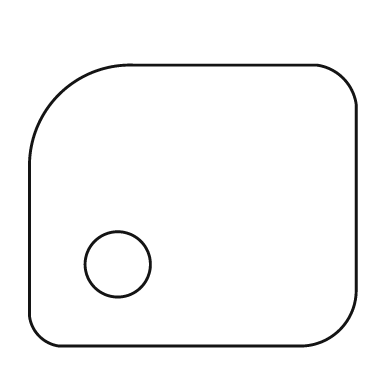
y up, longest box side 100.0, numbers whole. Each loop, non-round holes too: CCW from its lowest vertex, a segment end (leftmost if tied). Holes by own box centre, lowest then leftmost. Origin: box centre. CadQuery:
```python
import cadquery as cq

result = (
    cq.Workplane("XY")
    .moveTo(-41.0, -43.0)
    .lineTo(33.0, -43.0)
    .threePointArc((45.0, -38.0), (50.0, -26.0))
    .lineTo(50.0, 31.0)
    .threePointArc((46.0, 39.0), (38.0, 43.0))
    .lineTo(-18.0, 43.0)
    .threePointArc((-41.0, 34.0), (-50.0, 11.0))
    .lineTo(-50.0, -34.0)
    .threePointArc((-47.0, -40.0), (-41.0, -43.0))
    .close()
    .moveTo(-23.0, -18.0)
    .circle(10.0)
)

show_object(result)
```